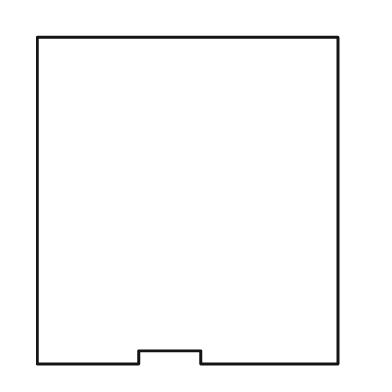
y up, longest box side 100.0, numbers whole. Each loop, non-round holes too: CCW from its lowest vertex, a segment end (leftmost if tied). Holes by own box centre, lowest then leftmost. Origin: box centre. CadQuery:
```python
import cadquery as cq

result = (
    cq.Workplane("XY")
    .moveTo(-46.0, -50.0)
    .lineTo(-15.0, -50.0)
    .lineTo(-15.0, -46.0)
    .lineTo(4.0, -46.0)
    .lineTo(4.0, -50.0)
    .lineTo(46.0, -50.0)
    .lineTo(46.0, 50.0)
    .lineTo(-46.0, 50.0)
    .close()
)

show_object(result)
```